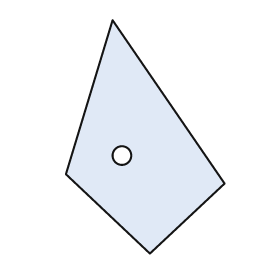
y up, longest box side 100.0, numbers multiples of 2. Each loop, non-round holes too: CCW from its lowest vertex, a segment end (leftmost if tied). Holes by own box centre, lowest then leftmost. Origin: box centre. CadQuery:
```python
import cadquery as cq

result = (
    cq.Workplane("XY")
    .moveTo(2.0, -50.0)
    .lineTo(34.0, -20.0)
    .lineTo(-14.0, 50.0)
    .lineTo(-34.0, -16.0)
    .close()
    .moveTo(-10.0, -8.0)
    .circle(4.0)
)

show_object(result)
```